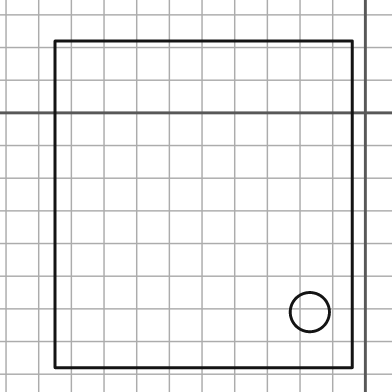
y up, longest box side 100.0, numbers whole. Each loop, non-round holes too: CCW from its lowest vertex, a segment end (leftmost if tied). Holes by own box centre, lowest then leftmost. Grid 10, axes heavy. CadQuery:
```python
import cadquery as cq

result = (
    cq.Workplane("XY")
    .moveTo(-95.0, -78.0)
    .lineTo(-4.0, -78.0)
    .lineTo(-4.0, 22.0)
    .lineTo(-95.0, 22.0)
    .close()
    .moveTo(-17.0, -61.0)
    .circle(6.0)
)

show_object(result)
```